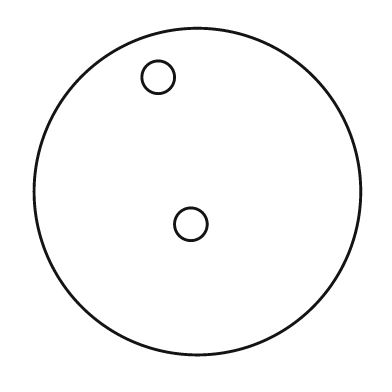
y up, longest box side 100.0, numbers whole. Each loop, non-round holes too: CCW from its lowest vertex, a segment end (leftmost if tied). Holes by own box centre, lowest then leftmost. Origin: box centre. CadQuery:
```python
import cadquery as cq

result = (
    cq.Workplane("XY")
    .moveTo(0.0, 0.0)
    .circle(50.0)
    .moveTo(-2.0, -10.0)
    .circle(5.0)
    .moveTo(-12.0, 35.0)
    .circle(5.0)
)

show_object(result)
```